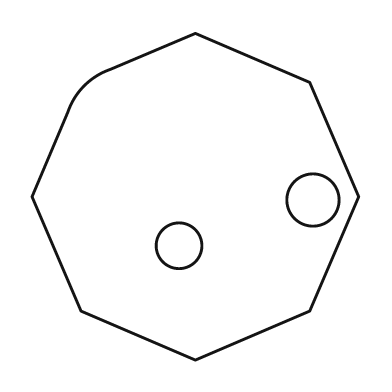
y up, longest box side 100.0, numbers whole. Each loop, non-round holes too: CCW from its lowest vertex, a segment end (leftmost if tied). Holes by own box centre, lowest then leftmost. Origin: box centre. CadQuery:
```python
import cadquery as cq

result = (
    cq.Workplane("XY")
    .moveTo(0.0, -50.0)
    .lineTo(35.0, -35.0)
    .lineTo(50.0, 0.0)
    .lineTo(35.0, 35.0)
    .lineTo(0.0, 50.0)
    .lineTo(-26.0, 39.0)
    .threePointArc((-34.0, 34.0), (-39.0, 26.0))
    .lineTo(-50.0, 0.0)
    .lineTo(-35.0, -35.0)
    .close()
    .moveTo(-5.0, -15.0)
    .circle(7.0)
    .moveTo(36.0, -1.0)
    .circle(8.0)
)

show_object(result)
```